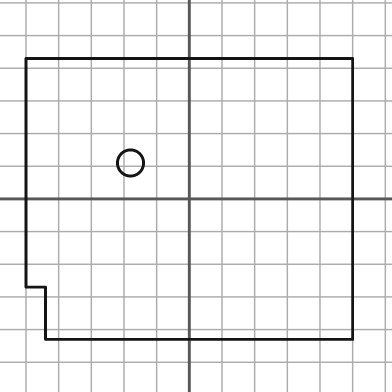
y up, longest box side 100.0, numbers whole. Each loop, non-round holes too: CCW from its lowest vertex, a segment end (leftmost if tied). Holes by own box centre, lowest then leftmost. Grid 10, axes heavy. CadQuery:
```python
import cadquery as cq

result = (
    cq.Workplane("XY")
    .moveTo(-44.0, -43.0)
    .lineTo(50.0, -43.0)
    .lineTo(50.0, 43.0)
    .lineTo(-50.0, 43.0)
    .lineTo(-50.0, -27.0)
    .lineTo(-44.0, -27.0)
    .close()
    .moveTo(-18.0, 11.0)
    .circle(4.0)
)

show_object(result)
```